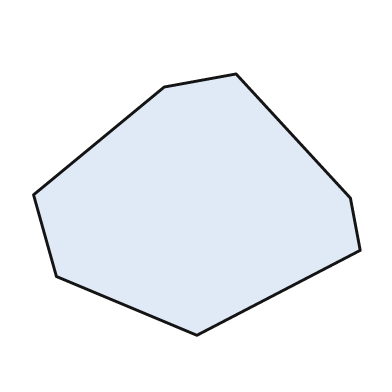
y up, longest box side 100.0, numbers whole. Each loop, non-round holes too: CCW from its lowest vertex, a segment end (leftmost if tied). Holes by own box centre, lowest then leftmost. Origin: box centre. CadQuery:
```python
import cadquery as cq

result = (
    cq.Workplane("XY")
    .moveTo(0.0, -40.0)
    .lineTo(50.0, -14.0)
    .lineTo(47.0, 2.0)
    .lineTo(12.0, 40.0)
    .lineTo(-10.0, 36.0)
    .lineTo(-50.0, 3.0)
    .lineTo(-43.0, -22.0)
    .close()
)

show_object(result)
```